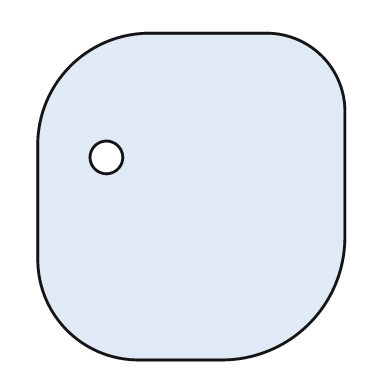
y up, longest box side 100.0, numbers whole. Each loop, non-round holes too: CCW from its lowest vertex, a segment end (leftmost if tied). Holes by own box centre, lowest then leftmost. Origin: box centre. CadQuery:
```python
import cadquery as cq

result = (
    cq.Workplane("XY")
    .moveTo(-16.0, -50.0)
    .lineTo(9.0, -50.0)
    .threePointArc((36.0, -39.0), (47.0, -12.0))
    .lineTo(47.0, 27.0)
    .threePointArc((40.0, 43.0), (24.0, 50.0))
    .lineTo(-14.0, 50.0)
    .threePointArc((-37.0, 40.0), (-47.0, 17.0))
    .lineTo(-47.0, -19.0)
    .threePointArc((-38.0, -41.0), (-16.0, -50.0))
    .close()
    .moveTo(-26.0, 12.0)
    .circle(5.0)
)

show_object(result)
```